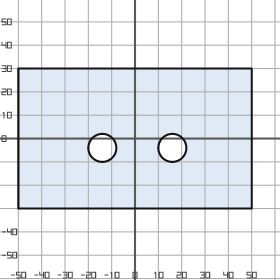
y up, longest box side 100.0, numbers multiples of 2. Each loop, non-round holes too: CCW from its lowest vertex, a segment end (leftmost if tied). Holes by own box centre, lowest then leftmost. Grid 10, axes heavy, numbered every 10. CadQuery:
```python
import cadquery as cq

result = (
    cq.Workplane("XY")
    .moveTo(-50.0, -30.0)
    .lineTo(50.0, -30.0)
    .lineTo(50.0, 30.0)
    .lineTo(-50.0, 30.0)
    .close()
    .moveTo(-14.0, -4.0)
    .circle(6.0)
    .moveTo(16.0, -4.0)
    .circle(6.0)
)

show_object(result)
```